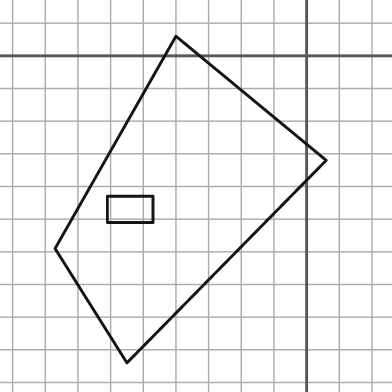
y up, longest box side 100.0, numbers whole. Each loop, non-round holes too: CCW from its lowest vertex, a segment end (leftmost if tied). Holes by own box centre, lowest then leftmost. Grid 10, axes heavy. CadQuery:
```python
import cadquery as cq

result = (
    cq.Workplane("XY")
    .moveTo(-55.0, -94.0)
    .lineTo(6.0, -32.0)
    .lineTo(-40.0, 6.0)
    .lineTo(-77.0, -59.0)
    .close()
    .moveTo(-61.0, -51.0)
    .lineTo(-47.0, -51.0)
    .lineTo(-47.0, -43.0)
    .lineTo(-61.0, -43.0)
    .close()
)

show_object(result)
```